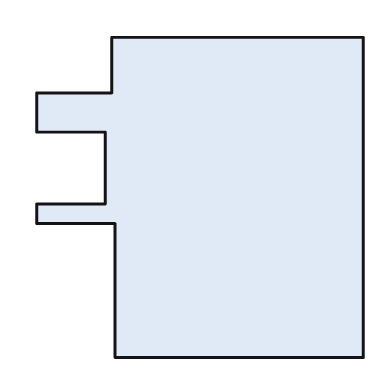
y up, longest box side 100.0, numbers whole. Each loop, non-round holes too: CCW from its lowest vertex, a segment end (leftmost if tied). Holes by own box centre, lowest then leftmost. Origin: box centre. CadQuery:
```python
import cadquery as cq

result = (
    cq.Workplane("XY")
    .moveTo(-26.0, -49.0)
    .lineTo(50.0, -49.0)
    .lineTo(50.0, 49.0)
    .lineTo(-27.0, 49.0)
    .lineTo(-27.0, 32.0)
    .lineTo(-50.0, 32.0)
    .lineTo(-50.0, 20.0)
    .lineTo(-29.0, 20.0)
    .lineTo(-29.0, -2.0)
    .lineTo(-50.0, -2.0)
    .lineTo(-50.0, -8.0)
    .lineTo(-26.0, -8.0)
    .close()
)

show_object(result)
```